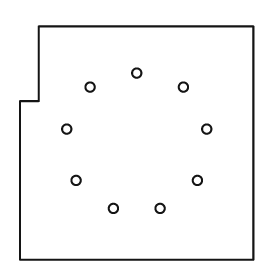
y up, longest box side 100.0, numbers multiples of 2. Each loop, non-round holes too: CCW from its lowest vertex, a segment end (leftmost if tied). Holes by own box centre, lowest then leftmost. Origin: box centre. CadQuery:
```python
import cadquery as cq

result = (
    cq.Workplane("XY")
    .moveTo(-50.0, -50.0)
    .lineTo(50.0, -50.0)
    .lineTo(50.0, 50.0)
    .lineTo(-42.0, 50.0)
    .lineTo(-42.0, 18.0)
    .lineTo(-50.0, 18.0)
    .close()
    .moveTo(-10.0, -28.0)
    .circle(2.0)
    .moveTo(10.0, -28.0)
    .circle(2.0)
    .moveTo(-26.0, -16.0)
    .circle(2.0)
    .moveTo(26.0, -16.0)
    .circle(2.0)
    .moveTo(-30.0, 6.0)
    .circle(2.0)
    .moveTo(30.0, 6.0)
    .circle(2.0)
    .moveTo(-20.0, 24.0)
    .circle(2.0)
    .moveTo(20.0, 24.0)
    .circle(2.0)
    .moveTo(0.0, 30.0)
    .circle(2.0)
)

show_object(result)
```